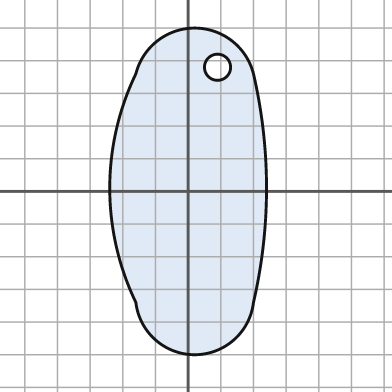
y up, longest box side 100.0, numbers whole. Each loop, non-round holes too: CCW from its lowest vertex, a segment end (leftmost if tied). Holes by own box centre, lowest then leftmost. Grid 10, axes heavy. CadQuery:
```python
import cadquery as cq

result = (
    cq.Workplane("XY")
    .moveTo(-16.0, -34.0)
    .threePointArc((2.0, -50.0), (20.0, -34.0))
    .threePointArc((24.0, 1.0), (20.0, 36.0))
    .threePointArc((2.0, 50.0), (-16.0, 36.0))
    .threePointArc((-24.0, 1.0), (-16.0, -34.0))
    .close()
    .moveTo(9.0, 38.0)
    .circle(4.0)
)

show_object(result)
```